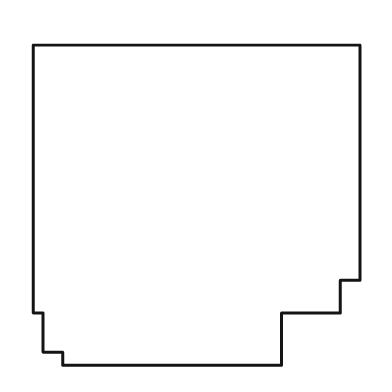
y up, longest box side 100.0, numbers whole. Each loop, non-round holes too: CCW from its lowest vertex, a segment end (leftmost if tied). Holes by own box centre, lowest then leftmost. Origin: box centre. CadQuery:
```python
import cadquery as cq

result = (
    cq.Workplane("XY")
    .moveTo(-41.0, -49.0)
    .lineTo(26.0, -49.0)
    .lineTo(26.0, -33.0)
    .lineTo(44.0, -33.0)
    .lineTo(44.0, -23.0)
    .lineTo(50.0, -23.0)
    .lineTo(50.0, 49.0)
    .lineTo(-50.0, 49.0)
    .lineTo(-50.0, -33.0)
    .lineTo(-47.0, -33.0)
    .lineTo(-47.0, -45.0)
    .lineTo(-41.0, -45.0)
    .close()
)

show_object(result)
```